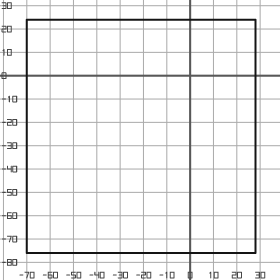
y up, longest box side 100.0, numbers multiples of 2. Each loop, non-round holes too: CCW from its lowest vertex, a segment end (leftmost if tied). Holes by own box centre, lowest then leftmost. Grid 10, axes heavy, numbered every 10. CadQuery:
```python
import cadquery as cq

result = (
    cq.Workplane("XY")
    .moveTo(-70.0, -76.0)
    .lineTo(28.0, -76.0)
    .lineTo(28.0, 24.0)
    .lineTo(-70.0, 24.0)
    .close()
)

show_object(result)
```